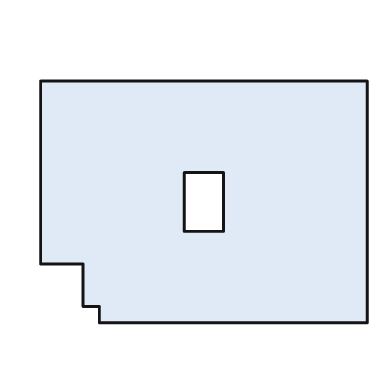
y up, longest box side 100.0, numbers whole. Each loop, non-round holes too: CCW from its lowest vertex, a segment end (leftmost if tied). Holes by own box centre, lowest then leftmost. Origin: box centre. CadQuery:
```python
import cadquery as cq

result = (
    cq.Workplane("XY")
    .moveTo(-32.0, -37.0)
    .lineTo(50.0, -37.0)
    .lineTo(50.0, 37.0)
    .lineTo(-50.0, 37.0)
    .lineTo(-50.0, -19.0)
    .lineTo(-37.0, -19.0)
    .lineTo(-37.0, -32.0)
    .lineTo(-32.0, -32.0)
    .close()
    .moveTo(-6.0, -9.0)
    .lineTo(6.0, -9.0)
    .lineTo(6.0, 9.0)
    .lineTo(-6.0, 9.0)
    .close()
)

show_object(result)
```